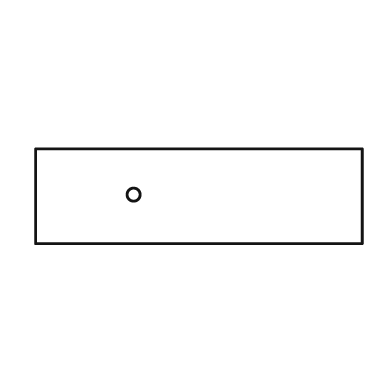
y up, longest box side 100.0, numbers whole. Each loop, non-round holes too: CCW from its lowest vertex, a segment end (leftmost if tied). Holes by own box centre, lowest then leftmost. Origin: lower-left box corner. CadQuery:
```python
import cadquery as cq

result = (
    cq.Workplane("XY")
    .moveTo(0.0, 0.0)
    .lineTo(100.0, 0.0)
    .lineTo(100.0, 29.0)
    .lineTo(0.0, 29.0)
    .close()
    .moveTo(30.0, 15.0)
    .circle(2.0)
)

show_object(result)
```